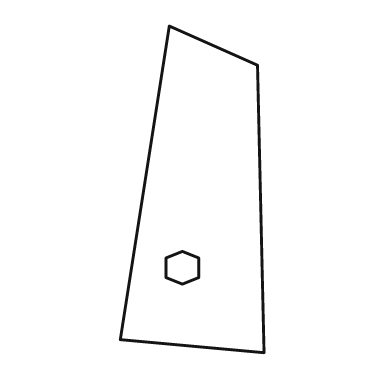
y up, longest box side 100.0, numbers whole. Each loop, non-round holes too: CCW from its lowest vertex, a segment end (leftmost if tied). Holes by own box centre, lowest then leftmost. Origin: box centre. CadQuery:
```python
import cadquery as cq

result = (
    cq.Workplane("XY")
    .moveTo(22.0, -50.0)
    .lineTo(20.0, 38.0)
    .lineTo(-7.0, 50.0)
    .lineTo(-22.0, -46.0)
    .close()
    .moveTo(-3.0, -29.0)
    .lineTo(2.0, -27.0)
    .lineTo(2.0, -21.0)
    .lineTo(-3.0, -19.0)
    .lineTo(-8.0, -21.0)
    .lineTo(-8.0, -27.0)
    .close()
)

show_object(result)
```